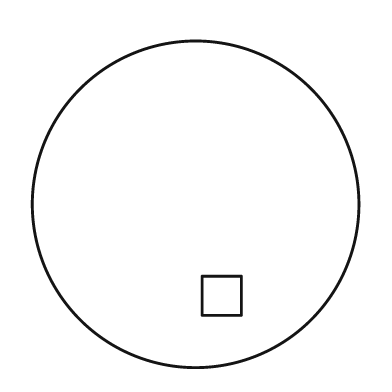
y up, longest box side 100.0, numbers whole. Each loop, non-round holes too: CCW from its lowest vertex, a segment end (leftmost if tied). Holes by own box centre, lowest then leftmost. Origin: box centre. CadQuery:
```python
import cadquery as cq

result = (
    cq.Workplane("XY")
    .moveTo(0.0, 0.0)
    .circle(50.0)
    .moveTo(2.0, -34.0)
    .lineTo(14.0, -34.0)
    .lineTo(14.0, -22.0)
    .lineTo(2.0, -22.0)
    .close()
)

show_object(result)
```